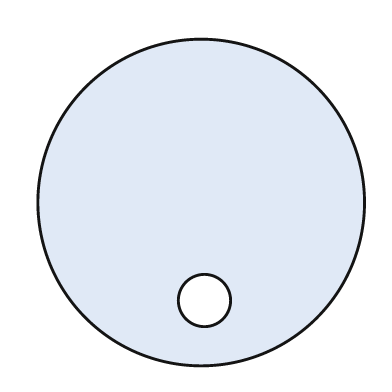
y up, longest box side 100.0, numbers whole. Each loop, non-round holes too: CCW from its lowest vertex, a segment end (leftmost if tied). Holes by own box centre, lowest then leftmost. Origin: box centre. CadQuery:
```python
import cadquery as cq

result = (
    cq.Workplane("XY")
    .moveTo(0.0, 0.0)
    .circle(50.0)
    .moveTo(1.0, -30.0)
    .circle(8.0)
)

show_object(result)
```